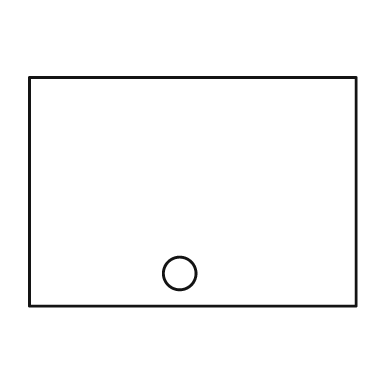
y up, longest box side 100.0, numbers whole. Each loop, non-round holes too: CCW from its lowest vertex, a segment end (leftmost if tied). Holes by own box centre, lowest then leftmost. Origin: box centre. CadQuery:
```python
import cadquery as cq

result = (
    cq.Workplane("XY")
    .moveTo(-50.0, -35.0)
    .lineTo(50.0, -35.0)
    .lineTo(50.0, 35.0)
    .lineTo(-50.0, 35.0)
    .close()
    .moveTo(-4.0, -25.0)
    .circle(5.0)
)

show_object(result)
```